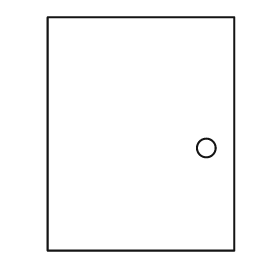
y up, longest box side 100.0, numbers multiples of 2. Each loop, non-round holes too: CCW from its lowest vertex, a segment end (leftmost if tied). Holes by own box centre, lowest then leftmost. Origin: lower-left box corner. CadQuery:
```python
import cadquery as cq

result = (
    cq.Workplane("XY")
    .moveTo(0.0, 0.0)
    .lineTo(80.0, 0.0)
    .lineTo(80.0, 100.0)
    .lineTo(0.0, 100.0)
    .close()
    .moveTo(68.0, 44.0)
    .circle(4.0)
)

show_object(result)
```